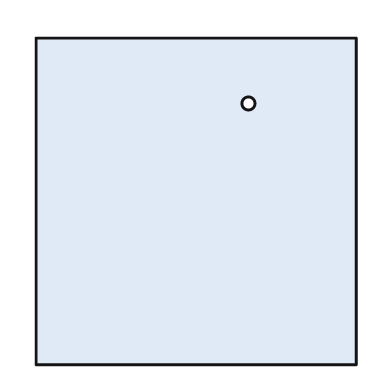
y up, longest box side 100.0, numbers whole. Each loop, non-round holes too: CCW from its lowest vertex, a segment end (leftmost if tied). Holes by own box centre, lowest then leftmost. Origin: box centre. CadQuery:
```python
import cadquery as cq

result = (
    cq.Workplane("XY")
    .moveTo(-49.0, -50.0)
    .lineTo(49.0, -50.0)
    .lineTo(49.0, 50.0)
    .lineTo(-49.0, 50.0)
    .close()
    .moveTo(16.0, 30.0)
    .circle(2.0)
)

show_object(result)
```